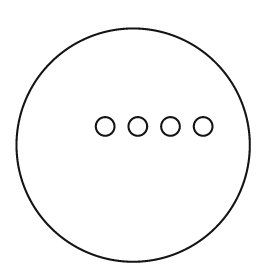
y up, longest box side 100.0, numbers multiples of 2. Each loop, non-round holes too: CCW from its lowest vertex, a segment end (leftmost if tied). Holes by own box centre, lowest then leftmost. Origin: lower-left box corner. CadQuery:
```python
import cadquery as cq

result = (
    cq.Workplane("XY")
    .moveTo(50.0, 50.0)
    .circle(50.0)
    .moveTo(38.0, 58.0)
    .circle(4.0)
    .moveTo(52.0, 58.0)
    .circle(4.0)
    .moveTo(66.0, 58.0)
    .circle(4.0)
    .moveTo(80.0, 58.0)
    .circle(4.0)
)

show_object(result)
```